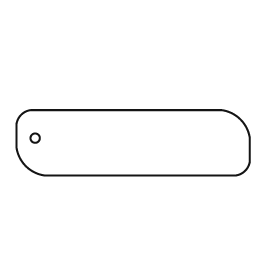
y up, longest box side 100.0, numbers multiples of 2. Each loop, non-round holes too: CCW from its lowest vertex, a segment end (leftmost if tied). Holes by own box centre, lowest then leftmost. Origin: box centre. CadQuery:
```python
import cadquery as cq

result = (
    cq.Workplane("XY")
    .moveTo(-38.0, -14.0)
    .lineTo(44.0, -14.0)
    .threePointArc((48.0, -12.0), (50.0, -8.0))
    .lineTo(50.0, 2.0)
    .threePointArc((46.0, 10.0), (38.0, 14.0))
    .lineTo(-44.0, 14.0)
    .threePointArc((-48.0, 12.0), (-50.0, 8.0))
    .lineTo(-50.0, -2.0)
    .threePointArc((-46.0, -10.0), (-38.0, -14.0))
    .close()
    .moveTo(-42.0, 2.0)
    .circle(2.0)
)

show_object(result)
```